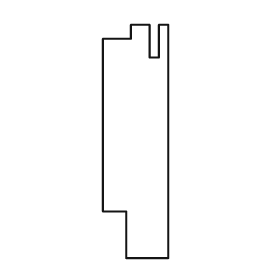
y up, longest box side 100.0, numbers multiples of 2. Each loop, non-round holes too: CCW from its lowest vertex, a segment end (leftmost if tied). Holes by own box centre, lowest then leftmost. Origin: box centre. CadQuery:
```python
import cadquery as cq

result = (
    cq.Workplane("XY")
    .moveTo(-4.0, -50.0)
    .lineTo(14.0, -50.0)
    .lineTo(14.0, 50.0)
    .lineTo(10.0, 50.0)
    .lineTo(10.0, 36.0)
    .lineTo(6.0, 36.0)
    .lineTo(6.0, 50.0)
    .lineTo(-2.0, 50.0)
    .lineTo(-2.0, 44.0)
    .lineTo(-14.0, 44.0)
    .lineTo(-14.0, -30.0)
    .lineTo(-4.0, -30.0)
    .close()
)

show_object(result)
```